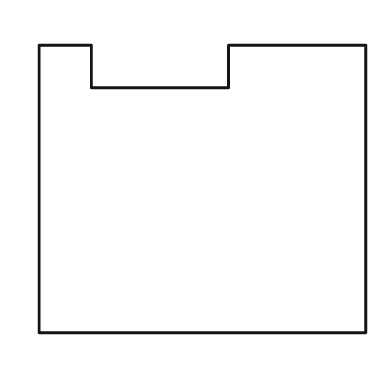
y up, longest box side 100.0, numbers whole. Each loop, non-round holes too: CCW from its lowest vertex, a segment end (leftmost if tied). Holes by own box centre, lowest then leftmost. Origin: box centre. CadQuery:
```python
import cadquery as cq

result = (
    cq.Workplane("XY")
    .moveTo(-50.0, -44.0)
    .lineTo(50.0, -44.0)
    .lineTo(50.0, 44.0)
    .lineTo(8.0, 44.0)
    .lineTo(8.0, 31.0)
    .lineTo(-34.0, 31.0)
    .lineTo(-34.0, 44.0)
    .lineTo(-50.0, 44.0)
    .close()
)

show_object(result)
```